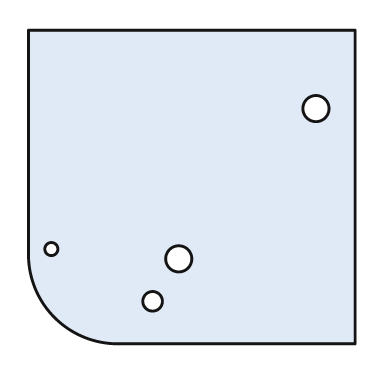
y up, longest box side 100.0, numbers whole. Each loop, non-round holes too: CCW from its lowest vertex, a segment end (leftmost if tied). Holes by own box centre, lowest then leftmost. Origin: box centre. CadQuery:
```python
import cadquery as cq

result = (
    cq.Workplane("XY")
    .moveTo(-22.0, -48.0)
    .lineTo(50.0, -48.0)
    .lineTo(50.0, 48.0)
    .lineTo(-50.0, 48.0)
    .lineTo(-50.0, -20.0)
    .threePointArc((-42.0, -40.0), (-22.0, -48.0))
    .close()
    .moveTo(-12.0, -35.0)
    .circle(3.0)
    .moveTo(-4.0, -22.0)
    .circle(4.0)
    .moveTo(-43.0, -19.0)
    .circle(2.0)
    .moveTo(38.0, 24.0)
    .circle(4.0)
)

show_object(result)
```